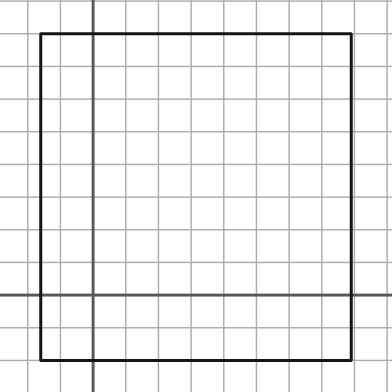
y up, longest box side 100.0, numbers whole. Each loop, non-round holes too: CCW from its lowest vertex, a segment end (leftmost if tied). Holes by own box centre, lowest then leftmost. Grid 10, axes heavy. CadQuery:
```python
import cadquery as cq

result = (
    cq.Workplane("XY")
    .moveTo(-16.0, -20.0)
    .lineTo(79.0, -20.0)
    .lineTo(79.0, 80.0)
    .lineTo(-16.0, 80.0)
    .close()
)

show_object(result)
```